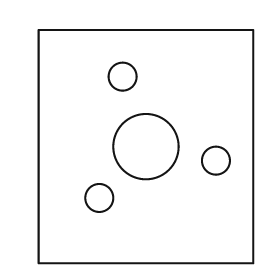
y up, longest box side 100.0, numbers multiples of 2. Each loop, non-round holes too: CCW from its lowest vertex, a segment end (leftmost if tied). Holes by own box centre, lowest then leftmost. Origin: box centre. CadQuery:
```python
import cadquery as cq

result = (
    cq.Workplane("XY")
    .moveTo(-46.0, -50.0)
    .lineTo(46.0, -50.0)
    .lineTo(46.0, 50.0)
    .lineTo(-46.0, 50.0)
    .close()
    .moveTo(-20.0, -22.0)
    .circle(6.0)
    .moveTo(30.0, -6.0)
    .circle(6.0)
    .moveTo(0.0, 0.0)
    .circle(14.0)
    .moveTo(-10.0, 30.0)
    .circle(6.0)
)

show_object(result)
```